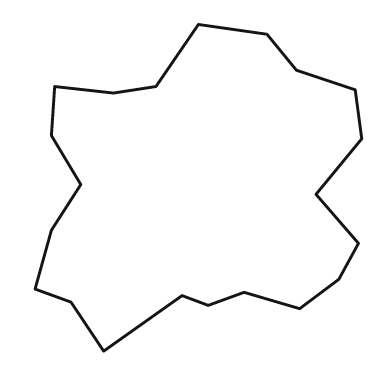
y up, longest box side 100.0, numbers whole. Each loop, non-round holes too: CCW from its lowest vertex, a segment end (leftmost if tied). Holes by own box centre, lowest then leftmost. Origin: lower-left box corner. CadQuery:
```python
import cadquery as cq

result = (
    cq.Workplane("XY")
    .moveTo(21.0, 0.0)
    .lineTo(45.0, 17.0)
    .lineTo(53.0, 14.0)
    .lineTo(64.0, 18.0)
    .lineTo(81.0, 13.0)
    .lineTo(93.0, 22.0)
    .lineTo(99.0, 33.0)
    .lineTo(86.0, 48.0)
    .lineTo(100.0, 65.0)
    .lineTo(98.0, 80.0)
    .lineTo(80.0, 86.0)
    .lineTo(71.0, 97.0)
    .lineTo(50.0, 100.0)
    .lineTo(37.0, 81.0)
    .lineTo(24.0, 79.0)
    .lineTo(6.0, 81.0)
    .lineTo(5.0, 66.0)
    .lineTo(14.0, 51.0)
    .lineTo(5.0, 37.0)
    .lineTo(0.0, 19.0)
    .lineTo(11.0, 15.0)
    .close()
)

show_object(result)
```